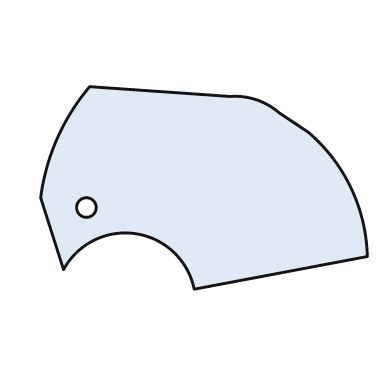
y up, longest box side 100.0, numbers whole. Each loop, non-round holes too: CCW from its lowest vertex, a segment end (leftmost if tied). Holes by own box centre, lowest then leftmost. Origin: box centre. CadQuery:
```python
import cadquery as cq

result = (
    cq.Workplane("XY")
    .moveTo(-3.0, -31.0)
    .lineTo(50.0, -21.0)
    .threePointArc((45.0, 0.0), (32.0, 17.0))
    .lineTo(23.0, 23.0)
    .threePointArc((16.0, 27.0), (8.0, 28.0))
    .lineTo(-35.0, 31.0)
    .threePointArc((-45.0, 15.0), (-50.0, -3.0))
    .lineTo(-43.0, -25.0)
    .threePointArc((-21.0, -14.0), (-3.0, -31.0))
    .close()
    .moveTo(-36.0, -6.0)
    .circle(3.0)
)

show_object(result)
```